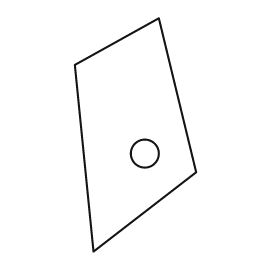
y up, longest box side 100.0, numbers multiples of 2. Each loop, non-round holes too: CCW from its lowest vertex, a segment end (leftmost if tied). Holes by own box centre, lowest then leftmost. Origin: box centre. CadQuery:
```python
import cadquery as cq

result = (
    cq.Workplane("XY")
    .moveTo(-18.0, -50.0)
    .lineTo(26.0, -16.0)
    .lineTo(10.0, 50.0)
    .lineTo(-26.0, 30.0)
    .close()
    .moveTo(4.0, -8.0)
    .circle(6.0)
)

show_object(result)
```